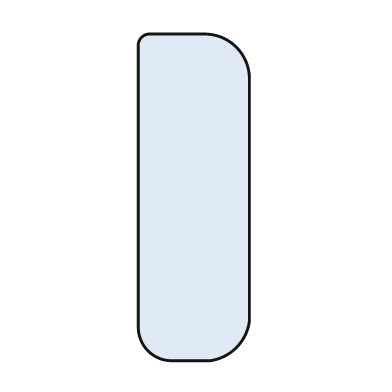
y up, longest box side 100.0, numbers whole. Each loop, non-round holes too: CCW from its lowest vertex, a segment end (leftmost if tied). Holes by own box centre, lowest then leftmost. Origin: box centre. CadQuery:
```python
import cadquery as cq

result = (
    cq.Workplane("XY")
    .moveTo(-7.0, -50.0)
    .lineTo(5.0, -50.0)
    .threePointArc((13.0, -46.0), (17.0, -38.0))
    .lineTo(17.0, 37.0)
    .threePointArc((13.0, 46.0), (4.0, 50.0))
    .lineTo(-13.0, 50.0)
    .threePointArc((-16.0, 49.0), (-17.0, 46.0))
    .lineTo(-17.0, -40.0)
    .threePointArc((-14.0, -47.0), (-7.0, -50.0))
    .close()
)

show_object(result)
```